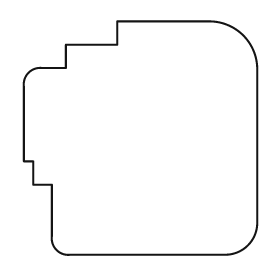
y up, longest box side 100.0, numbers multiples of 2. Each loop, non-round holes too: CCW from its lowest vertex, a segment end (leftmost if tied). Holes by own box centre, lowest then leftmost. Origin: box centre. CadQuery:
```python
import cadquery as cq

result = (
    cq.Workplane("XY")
    .moveTo(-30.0, -50.0)
    .lineTo(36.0, -50.0)
    .threePointArc((46.0, -46.0), (50.0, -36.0))
    .lineTo(50.0, 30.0)
    .threePointArc((44.0, 44.0), (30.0, 50.0))
    .lineTo(-10.0, 50.0)
    .lineTo(-10.0, 40.0)
    .lineTo(-32.0, 40.0)
    .lineTo(-32.0, 30.0)
    .lineTo(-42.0, 30.0)
    .threePointArc((-48.0, 28.0), (-50.0, 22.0))
    .lineTo(-50.0, -10.0)
    .lineTo(-46.0, -10.0)
    .lineTo(-46.0, -20.0)
    .lineTo(-38.0, -20.0)
    .lineTo(-38.0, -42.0)
    .threePointArc((-36.0, -48.0), (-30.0, -50.0))
    .close()
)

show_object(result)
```